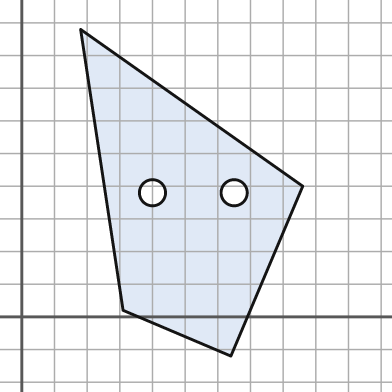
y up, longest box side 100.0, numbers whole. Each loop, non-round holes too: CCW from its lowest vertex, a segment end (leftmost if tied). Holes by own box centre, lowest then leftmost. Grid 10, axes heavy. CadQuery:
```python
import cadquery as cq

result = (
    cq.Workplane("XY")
    .moveTo(64.0, -12.0)
    .lineTo(86.0, 40.0)
    .lineTo(18.0, 88.0)
    .lineTo(31.0, 2.0)
    .close()
    .moveTo(40.0, 38.0)
    .circle(4.0)
    .moveTo(65.0, 38.0)
    .circle(4.0)
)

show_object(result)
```